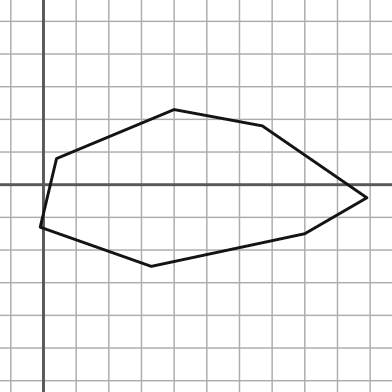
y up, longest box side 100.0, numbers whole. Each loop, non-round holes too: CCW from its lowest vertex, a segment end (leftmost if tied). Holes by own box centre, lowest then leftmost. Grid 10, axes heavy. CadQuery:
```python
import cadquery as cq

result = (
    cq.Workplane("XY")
    .moveTo(33.0, -25.0)
    .lineTo(80.0, -15.0)
    .lineTo(99.0, -4.0)
    .lineTo(67.0, 18.0)
    .lineTo(40.0, 23.0)
    .lineTo(4.0, 8.0)
    .lineTo(-1.0, -13.0)
    .close()
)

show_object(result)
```